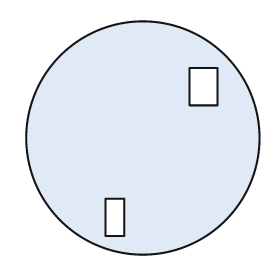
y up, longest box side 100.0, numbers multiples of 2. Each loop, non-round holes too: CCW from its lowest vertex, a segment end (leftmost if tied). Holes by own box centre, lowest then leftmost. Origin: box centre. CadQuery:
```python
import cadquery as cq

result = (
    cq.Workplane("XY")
    .moveTo(0.0, 0.0)
    .circle(50.0)
    .moveTo(-16.0, -42.0)
    .lineTo(-8.0, -42.0)
    .lineTo(-8.0, -26.0)
    .lineTo(-16.0, -26.0)
    .close()
    .moveTo(20.0, 14.0)
    .lineTo(32.0, 14.0)
    .lineTo(32.0, 30.0)
    .lineTo(20.0, 30.0)
    .close()
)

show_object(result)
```